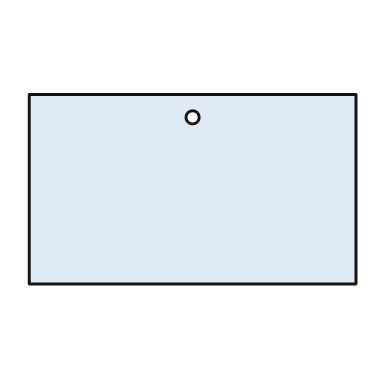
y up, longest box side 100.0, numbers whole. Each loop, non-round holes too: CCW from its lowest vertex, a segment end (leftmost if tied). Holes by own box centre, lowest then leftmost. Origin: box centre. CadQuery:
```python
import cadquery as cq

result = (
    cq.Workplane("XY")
    .moveTo(-50.0, -29.0)
    .lineTo(50.0, -29.0)
    .lineTo(50.0, 29.0)
    .lineTo(-50.0, 29.0)
    .close()
    .moveTo(0.0, 22.0)
    .circle(2.0)
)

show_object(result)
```